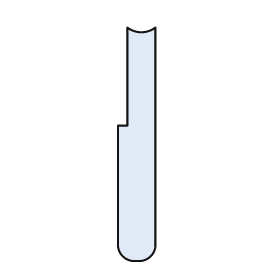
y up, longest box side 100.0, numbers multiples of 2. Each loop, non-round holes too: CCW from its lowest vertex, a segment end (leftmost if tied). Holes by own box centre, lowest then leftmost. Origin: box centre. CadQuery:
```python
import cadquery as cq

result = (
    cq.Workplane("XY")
    .moveTo(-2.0, -50.0)
    .lineTo(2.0, -50.0)
    .threePointArc((6.0, -48.0), (8.0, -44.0))
    .lineTo(8.0, 50.0)
    .threePointArc((2.0, 48.0), (-4.0, 50.0))
    .lineTo(-4.0, 8.0)
    .lineTo(-8.0, 8.0)
    .lineTo(-8.0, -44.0)
    .threePointArc((-6.0, -48.0), (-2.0, -50.0))
    .close()
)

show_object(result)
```